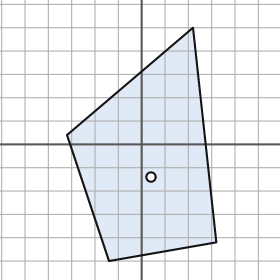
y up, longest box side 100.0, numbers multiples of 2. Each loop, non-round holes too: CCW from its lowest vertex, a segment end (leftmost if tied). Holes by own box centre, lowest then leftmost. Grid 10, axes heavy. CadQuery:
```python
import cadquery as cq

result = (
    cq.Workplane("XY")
    .moveTo(-14.0, -50.0)
    .lineTo(32.0, -42.0)
    .lineTo(22.0, 50.0)
    .lineTo(-32.0, 4.0)
    .close()
    .moveTo(4.0, -14.0)
    .circle(2.0)
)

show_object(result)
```